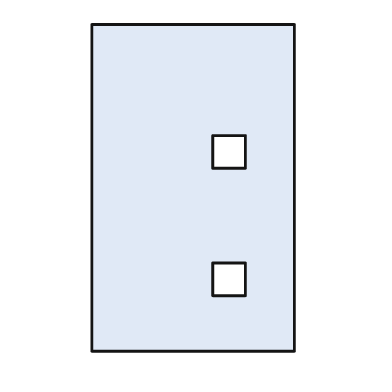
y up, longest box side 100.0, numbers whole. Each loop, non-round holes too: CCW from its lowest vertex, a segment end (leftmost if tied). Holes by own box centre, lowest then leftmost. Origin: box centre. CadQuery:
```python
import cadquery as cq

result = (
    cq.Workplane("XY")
    .moveTo(-31.0, -50.0)
    .lineTo(31.0, -50.0)
    .lineTo(31.0, 50.0)
    .lineTo(-31.0, 50.0)
    .close()
    .moveTo(6.0, -33.0)
    .lineTo(16.0, -33.0)
    .lineTo(16.0, -23.0)
    .lineTo(6.0, -23.0)
    .close()
    .moveTo(6.0, 6.0)
    .lineTo(16.0, 6.0)
    .lineTo(16.0, 16.0)
    .lineTo(6.0, 16.0)
    .close()
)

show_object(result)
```